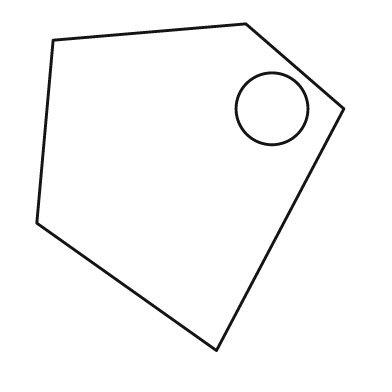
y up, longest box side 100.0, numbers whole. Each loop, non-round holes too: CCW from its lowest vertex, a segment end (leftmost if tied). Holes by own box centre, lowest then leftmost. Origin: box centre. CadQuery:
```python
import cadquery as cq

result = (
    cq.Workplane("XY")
    .moveTo(8.0, -50.0)
    .lineTo(47.0, 24.0)
    .lineTo(17.0, 50.0)
    .lineTo(-42.0, 45.0)
    .lineTo(-47.0, -11.0)
    .close()
    .moveTo(25.0, 24.0)
    .circle(11.0)
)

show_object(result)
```